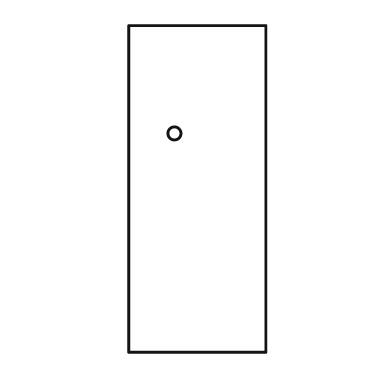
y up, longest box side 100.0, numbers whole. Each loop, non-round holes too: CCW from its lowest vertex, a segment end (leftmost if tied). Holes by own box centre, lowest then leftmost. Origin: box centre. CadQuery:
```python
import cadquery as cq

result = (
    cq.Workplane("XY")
    .moveTo(-21.0, -50.0)
    .lineTo(21.0, -50.0)
    .lineTo(21.0, 50.0)
    .lineTo(-21.0, 50.0)
    .close()
    .moveTo(-7.0, 17.0)
    .circle(2.0)
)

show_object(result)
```